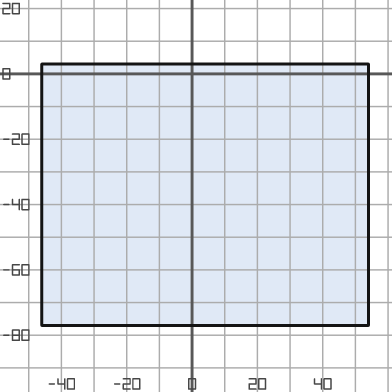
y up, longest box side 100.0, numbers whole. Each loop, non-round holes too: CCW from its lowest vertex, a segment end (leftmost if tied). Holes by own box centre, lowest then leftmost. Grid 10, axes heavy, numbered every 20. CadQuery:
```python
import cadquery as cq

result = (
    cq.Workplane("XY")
    .moveTo(-46.0, -77.0)
    .lineTo(54.0, -77.0)
    .lineTo(54.0, 3.0)
    .lineTo(-46.0, 3.0)
    .close()
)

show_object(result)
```